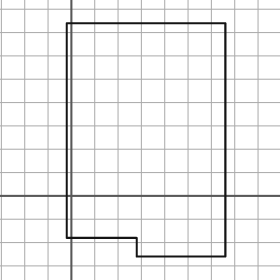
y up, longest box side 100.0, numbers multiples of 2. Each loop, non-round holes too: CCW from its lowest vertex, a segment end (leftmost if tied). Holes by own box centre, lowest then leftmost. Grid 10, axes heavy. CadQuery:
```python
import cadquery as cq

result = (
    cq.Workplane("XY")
    .moveTo(28.0, -26.0)
    .lineTo(66.0, -26.0)
    .lineTo(66.0, 74.0)
    .lineTo(-2.0, 74.0)
    .lineTo(-2.0, -18.0)
    .lineTo(28.0, -18.0)
    .close()
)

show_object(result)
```